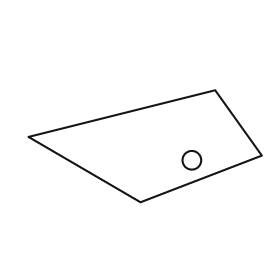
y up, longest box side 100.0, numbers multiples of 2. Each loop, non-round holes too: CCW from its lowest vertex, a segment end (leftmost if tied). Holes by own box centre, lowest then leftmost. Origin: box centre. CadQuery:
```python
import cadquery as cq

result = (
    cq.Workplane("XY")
    .moveTo(-2.0, -24.0)
    .lineTo(50.0, -4.0)
    .lineTo(30.0, 24.0)
    .lineTo(-50.0, 4.0)
    .close()
    .moveTo(20.0, -6.0)
    .circle(4.0)
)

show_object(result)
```